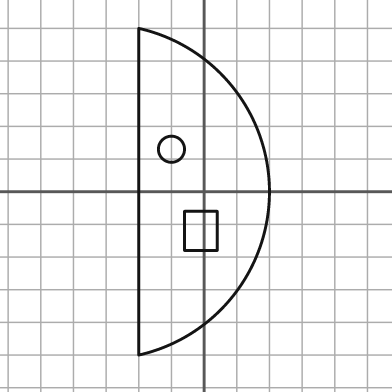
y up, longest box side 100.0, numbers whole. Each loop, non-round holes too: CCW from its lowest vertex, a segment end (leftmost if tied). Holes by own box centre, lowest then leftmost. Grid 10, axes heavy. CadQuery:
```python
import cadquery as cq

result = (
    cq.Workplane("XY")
    .moveTo(-20.0, -50.0)
    .threePointArc((20.0, 0.0), (-20.0, 50.0))
    .close()
    .moveTo(-6.0, -18.0)
    .lineTo(4.0, -18.0)
    .lineTo(4.0, -6.0)
    .lineTo(-6.0, -6.0)
    .close()
    .moveTo(-10.0, 13.0)
    .circle(4.0)
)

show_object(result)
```